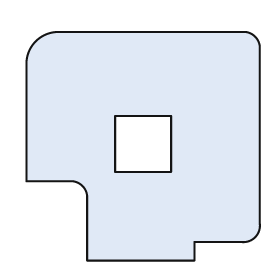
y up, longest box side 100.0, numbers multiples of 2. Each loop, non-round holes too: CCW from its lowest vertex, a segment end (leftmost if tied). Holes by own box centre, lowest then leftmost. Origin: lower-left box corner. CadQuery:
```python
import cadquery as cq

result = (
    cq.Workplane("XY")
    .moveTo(26.0, 0.0)
    .lineTo(72.0, 0.0)
    .lineTo(72.0, 8.0)
    .lineTo(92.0, 8.0)
    .threePointArc((98.0, 10.0), (100.0, 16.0))
    .lineTo(100.0, 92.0)
    .threePointArc((98.0, 96.0), (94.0, 98.0))
    .lineTo(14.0, 98.0)
    .threePointArc((4.0, 94.0), (0.0, 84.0))
    .lineTo(0.0, 34.0)
    .lineTo(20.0, 34.0)
    .threePointArc((24.0, 32.0), (26.0, 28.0))
    .close()
    .moveTo(38.0, 38.0)
    .lineTo(62.0, 38.0)
    .lineTo(62.0, 62.0)
    .lineTo(38.0, 62.0)
    .close()
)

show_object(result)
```